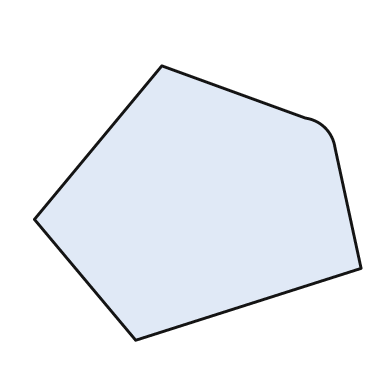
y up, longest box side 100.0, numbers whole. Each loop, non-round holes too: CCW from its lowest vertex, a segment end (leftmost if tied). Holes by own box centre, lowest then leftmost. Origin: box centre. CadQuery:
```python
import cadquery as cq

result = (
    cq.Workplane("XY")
    .moveTo(-19.0, -42.0)
    .lineTo(50.0, -20.0)
    .lineTo(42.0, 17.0)
    .threePointArc((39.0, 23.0), (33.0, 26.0))
    .lineTo(-11.0, 42.0)
    .lineTo(-50.0, -5.0)
    .close()
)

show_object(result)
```